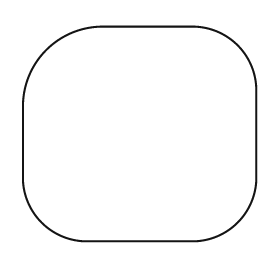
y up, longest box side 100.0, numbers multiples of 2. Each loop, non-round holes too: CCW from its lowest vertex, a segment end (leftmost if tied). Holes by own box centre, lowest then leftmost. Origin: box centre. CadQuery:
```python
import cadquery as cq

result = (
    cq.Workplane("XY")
    .moveTo(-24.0, -46.0)
    .lineTo(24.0, -46.0)
    .threePointArc((42.0, -38.0), (50.0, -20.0))
    .lineTo(50.0, 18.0)
    .threePointArc((42.0, 38.0), (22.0, 46.0))
    .lineTo(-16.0, 46.0)
    .threePointArc((-40.0, 36.0), (-50.0, 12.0))
    .lineTo(-50.0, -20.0)
    .threePointArc((-42.0, -38.0), (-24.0, -46.0))
    .close()
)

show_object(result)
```